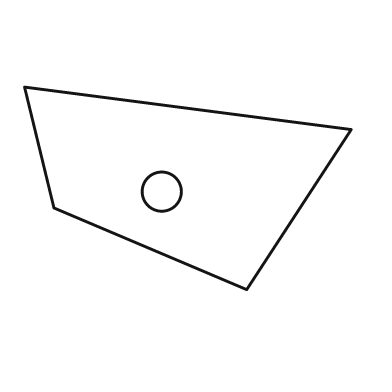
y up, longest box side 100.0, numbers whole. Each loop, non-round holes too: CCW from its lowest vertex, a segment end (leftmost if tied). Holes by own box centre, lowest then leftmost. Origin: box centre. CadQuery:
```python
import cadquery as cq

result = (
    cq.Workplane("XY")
    .moveTo(18.0, -31.0)
    .lineTo(50.0, 18.0)
    .lineTo(-50.0, 31.0)
    .lineTo(-41.0, -6.0)
    .close()
    .moveTo(-8.0, -1.0)
    .circle(6.0)
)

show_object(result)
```